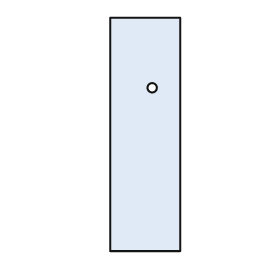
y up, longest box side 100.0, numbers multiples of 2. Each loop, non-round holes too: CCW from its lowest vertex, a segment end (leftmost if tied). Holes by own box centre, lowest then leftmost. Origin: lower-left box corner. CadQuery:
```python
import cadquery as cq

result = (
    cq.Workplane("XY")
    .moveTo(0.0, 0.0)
    .lineTo(30.0, 0.0)
    .lineTo(30.0, 100.0)
    .lineTo(0.0, 100.0)
    .close()
    .moveTo(18.0, 70.0)
    .circle(2.0)
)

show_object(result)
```